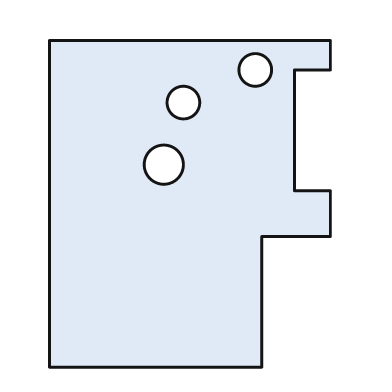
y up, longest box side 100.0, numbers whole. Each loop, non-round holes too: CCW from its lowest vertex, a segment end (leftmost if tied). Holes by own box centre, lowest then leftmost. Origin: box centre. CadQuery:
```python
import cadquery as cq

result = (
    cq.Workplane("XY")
    .moveTo(-43.0, -50.0)
    .lineTo(22.0, -50.0)
    .lineTo(22.0, -10.0)
    .lineTo(43.0, -10.0)
    .lineTo(43.0, 4.0)
    .lineTo(32.0, 4.0)
    .lineTo(32.0, 41.0)
    .lineTo(43.0, 41.0)
    .lineTo(43.0, 50.0)
    .lineTo(-43.0, 50.0)
    .close()
    .moveTo(-8.0, 12.0)
    .circle(6.0)
    .moveTo(-2.0, 31.0)
    .circle(5.0)
    .moveTo(20.0, 41.0)
    .circle(5.0)
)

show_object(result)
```